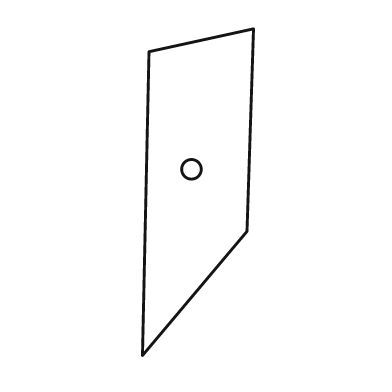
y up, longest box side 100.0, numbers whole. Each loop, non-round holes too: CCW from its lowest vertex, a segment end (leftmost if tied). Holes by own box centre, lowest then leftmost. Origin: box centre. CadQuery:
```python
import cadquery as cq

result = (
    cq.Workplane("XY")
    .moveTo(-17.0, -50.0)
    .lineTo(15.0, -12.0)
    .lineTo(17.0, 50.0)
    .lineTo(-15.0, 43.0)
    .close()
    .moveTo(-2.0, 7.0)
    .circle(3.0)
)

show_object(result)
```